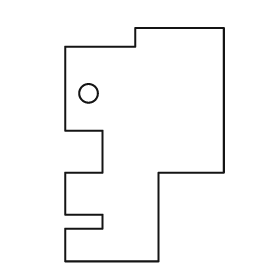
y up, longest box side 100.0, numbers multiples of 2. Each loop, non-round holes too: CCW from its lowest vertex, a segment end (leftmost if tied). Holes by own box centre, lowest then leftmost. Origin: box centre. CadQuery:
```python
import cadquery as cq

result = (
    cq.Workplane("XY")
    .moveTo(-34.0, -50.0)
    .lineTo(6.0, -50.0)
    .lineTo(6.0, -12.0)
    .lineTo(34.0, -12.0)
    .lineTo(34.0, 50.0)
    .lineTo(-4.0, 50.0)
    .lineTo(-4.0, 42.0)
    .lineTo(-34.0, 42.0)
    .lineTo(-34.0, 6.0)
    .lineTo(-18.0, 6.0)
    .lineTo(-18.0, -12.0)
    .lineTo(-34.0, -12.0)
    .lineTo(-34.0, -30.0)
    .lineTo(-18.0, -30.0)
    .lineTo(-18.0, -36.0)
    .lineTo(-34.0, -36.0)
    .close()
    .moveTo(-24.0, 22.0)
    .circle(4.0)
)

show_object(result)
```